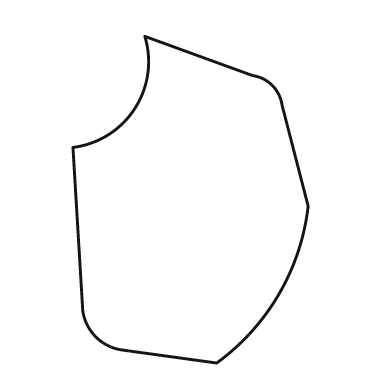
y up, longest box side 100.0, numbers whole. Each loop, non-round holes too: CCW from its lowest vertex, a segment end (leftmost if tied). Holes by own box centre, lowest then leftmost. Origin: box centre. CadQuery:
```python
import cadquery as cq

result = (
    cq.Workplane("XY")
    .moveTo(8.0, -50.0)
    .threePointArc((27.0, -29.0), (36.0, -2.0))
    .lineTo(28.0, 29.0)
    .threePointArc((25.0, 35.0), (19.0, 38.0))
    .lineTo(-14.0, 50.0)
    .threePointArc((-17.0, 28.0), (-36.0, 16.0))
    .lineTo(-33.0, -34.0)
    .threePointArc((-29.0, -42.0), (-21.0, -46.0))
    .close()
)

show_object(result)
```